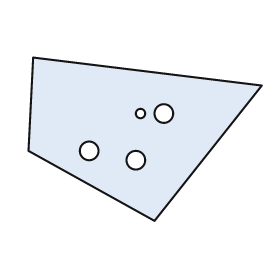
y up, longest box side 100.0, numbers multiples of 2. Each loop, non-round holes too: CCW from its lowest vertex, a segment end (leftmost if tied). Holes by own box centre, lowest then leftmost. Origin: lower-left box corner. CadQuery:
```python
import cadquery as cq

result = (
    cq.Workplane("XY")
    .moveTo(54.0, 0.0)
    .lineTo(100.0, 58.0)
    .lineTo(2.0, 70.0)
    .lineTo(0.0, 30.0)
    .close()
    .moveTo(46.0, 26.0)
    .circle(4.0)
    .moveTo(26.0, 30.0)
    .circle(4.0)
    .moveTo(48.0, 46.0)
    .circle(2.0)
    .moveTo(58.0, 46.0)
    .circle(4.0)
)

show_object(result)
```